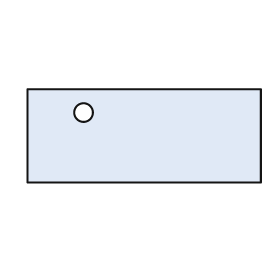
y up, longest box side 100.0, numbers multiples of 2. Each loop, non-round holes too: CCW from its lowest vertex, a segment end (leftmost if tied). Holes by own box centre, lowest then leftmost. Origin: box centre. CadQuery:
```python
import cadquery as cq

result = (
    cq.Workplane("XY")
    .moveTo(-50.0, -20.0)
    .lineTo(50.0, -20.0)
    .lineTo(50.0, 20.0)
    .lineTo(-50.0, 20.0)
    .close()
    .moveTo(-26.0, 10.0)
    .circle(4.0)
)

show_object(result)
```